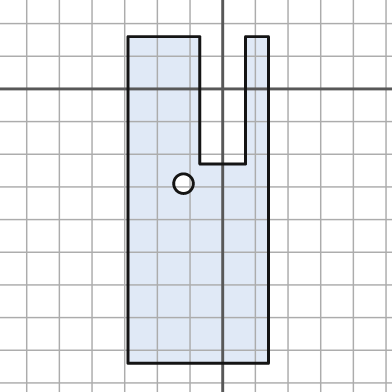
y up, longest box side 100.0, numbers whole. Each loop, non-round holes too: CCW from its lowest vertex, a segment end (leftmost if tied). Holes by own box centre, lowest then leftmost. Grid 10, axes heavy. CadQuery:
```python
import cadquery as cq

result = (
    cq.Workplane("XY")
    .moveTo(-29.0, -84.0)
    .lineTo(14.0, -84.0)
    .lineTo(14.0, 16.0)
    .lineTo(7.0, 16.0)
    .lineTo(7.0, -23.0)
    .lineTo(-7.0, -23.0)
    .lineTo(-7.0, 16.0)
    .lineTo(-29.0, 16.0)
    .close()
    .moveTo(-12.0, -29.0)
    .circle(3.0)
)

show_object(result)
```